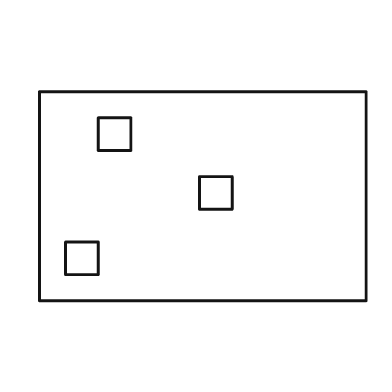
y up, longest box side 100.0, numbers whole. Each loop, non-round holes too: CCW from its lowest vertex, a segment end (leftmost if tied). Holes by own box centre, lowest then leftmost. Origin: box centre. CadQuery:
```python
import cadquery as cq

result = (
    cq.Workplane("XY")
    .moveTo(-50.0, -32.0)
    .lineTo(50.0, -32.0)
    .lineTo(50.0, 32.0)
    .lineTo(-50.0, 32.0)
    .close()
    .moveTo(-42.0, -24.0)
    .lineTo(-32.0, -24.0)
    .lineTo(-32.0, -14.0)
    .lineTo(-42.0, -14.0)
    .close()
    .moveTo(-1.0, -4.0)
    .lineTo(9.0, -4.0)
    .lineTo(9.0, 6.0)
    .lineTo(-1.0, 6.0)
    .close()
    .moveTo(-32.0, 14.0)
    .lineTo(-22.0, 14.0)
    .lineTo(-22.0, 24.0)
    .lineTo(-32.0, 24.0)
    .close()
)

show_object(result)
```